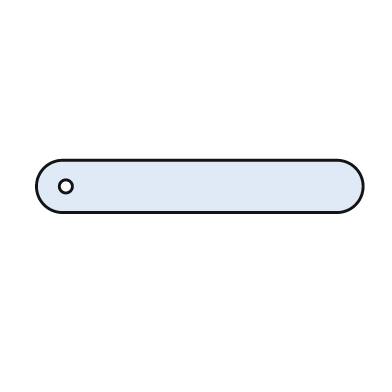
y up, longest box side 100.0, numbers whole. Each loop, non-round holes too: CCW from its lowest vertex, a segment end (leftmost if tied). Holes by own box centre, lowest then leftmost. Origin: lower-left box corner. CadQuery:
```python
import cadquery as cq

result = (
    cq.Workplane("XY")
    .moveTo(8.0, 0.0)
    .lineTo(92.0, 0.0)
    .threePointArc((100.0, 8.0), (92.0, 16.0))
    .lineTo(8.0, 16.0)
    .threePointArc((0.0, 8.0), (8.0, 0.0))
    .close()
    .moveTo(9.0, 8.0)
    .circle(2.0)
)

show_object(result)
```